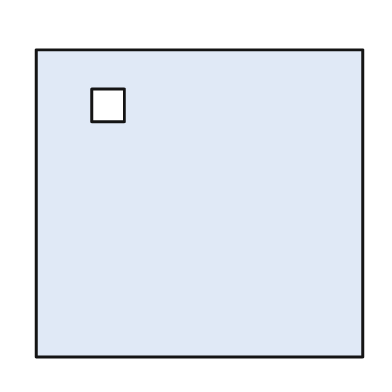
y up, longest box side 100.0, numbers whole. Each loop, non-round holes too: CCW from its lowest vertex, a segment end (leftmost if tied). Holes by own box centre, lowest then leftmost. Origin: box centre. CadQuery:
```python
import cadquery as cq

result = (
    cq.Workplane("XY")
    .moveTo(-50.0, -47.0)
    .lineTo(50.0, -47.0)
    .lineTo(50.0, 47.0)
    .lineTo(-50.0, 47.0)
    .close()
    .moveTo(-33.0, 25.0)
    .lineTo(-23.0, 25.0)
    .lineTo(-23.0, 35.0)
    .lineTo(-33.0, 35.0)
    .close()
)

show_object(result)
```